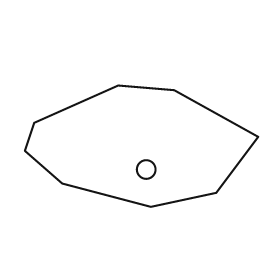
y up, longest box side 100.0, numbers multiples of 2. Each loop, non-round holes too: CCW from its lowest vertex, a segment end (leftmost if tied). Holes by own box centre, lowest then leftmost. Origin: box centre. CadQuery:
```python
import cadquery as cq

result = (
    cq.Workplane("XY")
    .moveTo(4.0, -26.0)
    .lineTo(32.0, -20.0)
    .lineTo(50.0, 4.0)
    .lineTo(14.0, 24.0)
    .lineTo(-10.0, 26.0)
    .lineTo(-46.0, 10.0)
    .lineTo(-50.0, -2.0)
    .lineTo(-34.0, -16.0)
    .close()
    .moveTo(2.0, -10.0)
    .circle(4.0)
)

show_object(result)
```